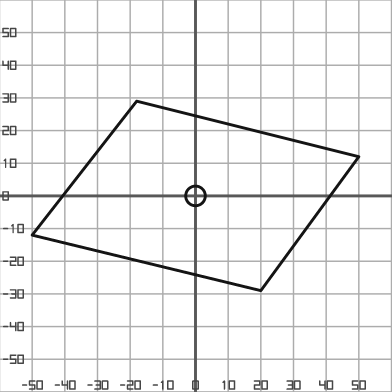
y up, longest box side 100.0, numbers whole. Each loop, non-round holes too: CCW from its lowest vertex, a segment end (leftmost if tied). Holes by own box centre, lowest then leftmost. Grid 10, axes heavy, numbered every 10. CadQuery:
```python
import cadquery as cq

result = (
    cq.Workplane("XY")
    .moveTo(20.0, -29.0)
    .lineTo(50.0, 12.0)
    .lineTo(-18.0, 29.0)
    .lineTo(-50.0, -12.0)
    .close()
    .moveTo(0.0, 0.0)
    .circle(3.0)
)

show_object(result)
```